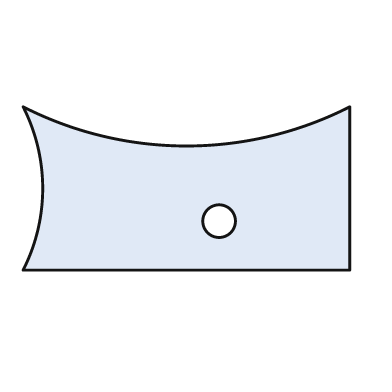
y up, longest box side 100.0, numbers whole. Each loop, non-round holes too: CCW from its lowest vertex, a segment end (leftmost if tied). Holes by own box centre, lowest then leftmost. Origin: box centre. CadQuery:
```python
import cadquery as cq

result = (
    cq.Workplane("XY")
    .moveTo(-50.0, -25.0)
    .lineTo(50.0, -25.0)
    .lineTo(50.0, 25.0)
    .threePointArc((0.0, 13.0), (-50.0, 25.0))
    .threePointArc((-44.0, 0.0), (-50.0, -25.0))
    .close()
    .moveTo(10.0, -10.0)
    .circle(5.0)
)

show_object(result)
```